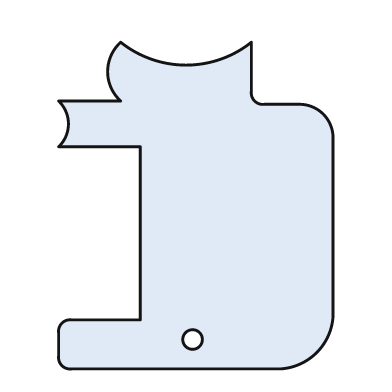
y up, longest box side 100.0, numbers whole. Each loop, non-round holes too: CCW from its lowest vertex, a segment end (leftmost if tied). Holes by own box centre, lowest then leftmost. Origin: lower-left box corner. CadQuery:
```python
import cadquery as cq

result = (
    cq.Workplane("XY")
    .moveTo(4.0, 0.0)
    .lineTo(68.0, 0.0)
    .threePointArc((79.0, 5.0), (84.0, 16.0))
    .lineTo(84.0, 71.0)
    .threePointArc((81.0, 78.0), (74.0, 81.0))
    .lineTo(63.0, 81.0)
    .threePointArc((60.0, 82.0), (59.0, 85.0))
    .lineTo(59.0, 100.0)
    .threePointArc((39.0, 93.0), (19.0, 100.0))
    .threePointArc((15.0, 91.0), (19.0, 82.0))
    .lineTo(0.0, 82.0)
    .threePointArc((3.0, 75.0), (0.0, 68.0))
    .lineTo(25.0, 68.0)
    .lineTo(25.0, 15.0)
    .lineTo(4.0, 15.0)
    .threePointArc((1.0, 14.0), (0.0, 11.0))
    .lineTo(0.0, 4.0)
    .threePointArc((1.0, 1.0), (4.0, 0.0))
    .close()
    .moveTo(41.0, 9.0)
    .circle(3.0)
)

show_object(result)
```